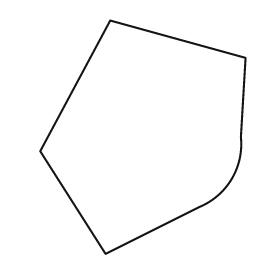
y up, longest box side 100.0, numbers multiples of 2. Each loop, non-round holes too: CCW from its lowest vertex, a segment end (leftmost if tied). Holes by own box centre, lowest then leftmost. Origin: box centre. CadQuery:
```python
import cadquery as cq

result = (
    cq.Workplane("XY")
    .moveTo(-16.0, -50.0)
    .lineTo(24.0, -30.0)
    .threePointArc((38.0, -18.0), (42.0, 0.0))
    .lineTo(44.0, 34.0)
    .lineTo(-14.0, 50.0)
    .lineTo(-44.0, -6.0)
    .close()
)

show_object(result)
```